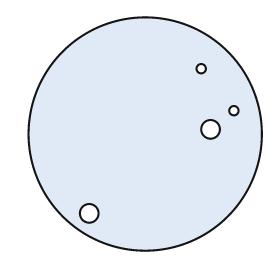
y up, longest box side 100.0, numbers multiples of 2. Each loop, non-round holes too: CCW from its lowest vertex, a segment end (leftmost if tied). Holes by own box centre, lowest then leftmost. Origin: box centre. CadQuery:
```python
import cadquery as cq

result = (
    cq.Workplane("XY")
    .moveTo(0.0, 0.0)
    .circle(50.0)
    .moveTo(-24.0, -34.0)
    .circle(4.0)
    .moveTo(28.0, 2.0)
    .circle(4.0)
    .moveTo(38.0, 10.0)
    .circle(2.0)
    .moveTo(24.0, 28.0)
    .circle(2.0)
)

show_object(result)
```